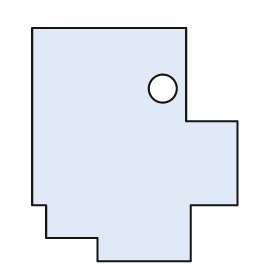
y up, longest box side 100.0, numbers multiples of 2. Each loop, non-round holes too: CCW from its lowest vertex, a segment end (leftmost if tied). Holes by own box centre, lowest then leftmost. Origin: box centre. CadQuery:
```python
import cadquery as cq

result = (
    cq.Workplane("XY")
    .moveTo(-16.0, -50.0)
    .lineTo(24.0, -50.0)
    .lineTo(24.0, -26.0)
    .lineTo(44.0, -26.0)
    .lineTo(44.0, 10.0)
    .lineTo(22.0, 10.0)
    .lineTo(22.0, 50.0)
    .lineTo(-44.0, 50.0)
    .lineTo(-44.0, -26.0)
    .lineTo(-38.0, -26.0)
    .lineTo(-38.0, -40.0)
    .lineTo(-16.0, -40.0)
    .close()
    .moveTo(12.0, 24.0)
    .circle(6.0)
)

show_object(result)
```